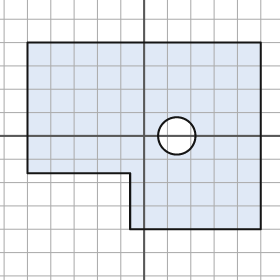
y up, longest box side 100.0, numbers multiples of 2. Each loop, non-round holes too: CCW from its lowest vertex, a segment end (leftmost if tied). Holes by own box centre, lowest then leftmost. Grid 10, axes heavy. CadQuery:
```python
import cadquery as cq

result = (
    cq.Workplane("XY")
    .moveTo(-6.0, -40.0)
    .lineTo(50.0, -40.0)
    .lineTo(50.0, 40.0)
    .lineTo(-50.0, 40.0)
    .lineTo(-50.0, -16.0)
    .lineTo(-6.0, -16.0)
    .close()
    .moveTo(14.0, 0.0)
    .circle(8.0)
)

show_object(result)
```